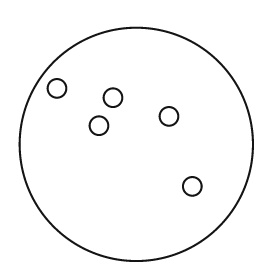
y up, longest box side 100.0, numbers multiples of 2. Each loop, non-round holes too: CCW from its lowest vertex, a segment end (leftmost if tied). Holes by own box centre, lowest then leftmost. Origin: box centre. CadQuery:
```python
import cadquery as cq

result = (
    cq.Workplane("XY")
    .moveTo(0.0, 0.0)
    .circle(50.0)
    .moveTo(24.0, -18.0)
    .circle(4.0)
    .moveTo(-16.0, 8.0)
    .circle(4.0)
    .moveTo(14.0, 12.0)
    .circle(4.0)
    .moveTo(-10.0, 20.0)
    .circle(4.0)
    .moveTo(-34.0, 24.0)
    .circle(4.0)
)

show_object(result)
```